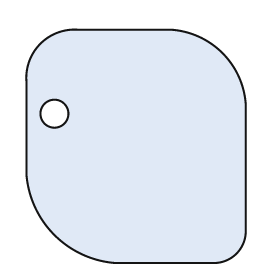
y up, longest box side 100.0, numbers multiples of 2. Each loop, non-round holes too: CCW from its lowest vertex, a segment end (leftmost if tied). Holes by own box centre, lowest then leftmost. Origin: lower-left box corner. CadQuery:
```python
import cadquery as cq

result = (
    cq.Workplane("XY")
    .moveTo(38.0, 0.0)
    .lineTo(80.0, 0.0)
    .threePointArc((90.0, 4.0), (94.0, 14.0))
    .lineTo(94.0, 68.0)
    .threePointArc((84.0, 90.0), (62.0, 100.0))
    .lineTo(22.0, 100.0)
    .threePointArc((6.0, 94.0), (0.0, 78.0))
    .lineTo(0.0, 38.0)
    .threePointArc((12.0, 12.0), (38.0, 0.0))
    .close()
    .moveTo(12.0, 64.0)
    .circle(6.0)
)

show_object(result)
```